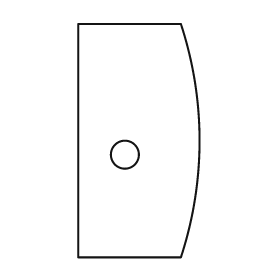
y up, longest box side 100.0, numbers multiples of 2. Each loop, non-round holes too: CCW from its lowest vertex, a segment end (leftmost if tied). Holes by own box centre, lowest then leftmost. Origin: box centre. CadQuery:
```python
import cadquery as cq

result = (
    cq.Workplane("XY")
    .moveTo(-26.0, -50.0)
    .lineTo(18.0, -50.0)
    .threePointArc((26.0, 0.0), (18.0, 50.0))
    .lineTo(-26.0, 50.0)
    .close()
    .moveTo(-6.0, -6.0)
    .circle(6.0)
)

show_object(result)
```